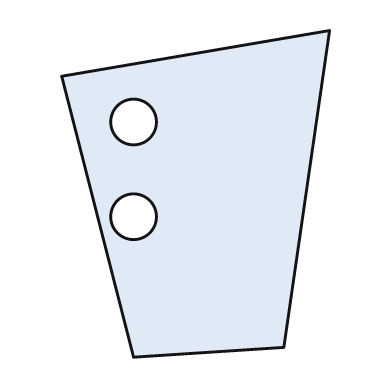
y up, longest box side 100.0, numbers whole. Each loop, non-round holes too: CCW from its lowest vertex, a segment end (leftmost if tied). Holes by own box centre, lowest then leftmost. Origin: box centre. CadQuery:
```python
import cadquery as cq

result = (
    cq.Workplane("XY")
    .moveTo(-19.0, -50.0)
    .lineTo(27.0, -47.0)
    .lineTo(41.0, 50.0)
    .lineTo(-41.0, 36.0)
    .close()
    .moveTo(-19.0, -7.0)
    .circle(7.0)
    .moveTo(-19.0, 22.0)
    .circle(7.0)
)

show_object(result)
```